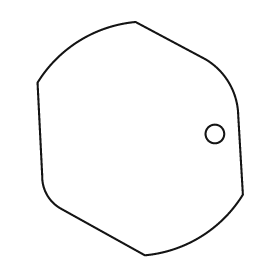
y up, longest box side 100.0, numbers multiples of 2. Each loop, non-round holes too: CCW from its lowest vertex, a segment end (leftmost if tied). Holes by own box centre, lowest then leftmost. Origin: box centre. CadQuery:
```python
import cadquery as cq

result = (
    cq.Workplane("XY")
    .moveTo(2.0, -50.0)
    .threePointArc((26.0, -42.0), (44.0, -24.0))
    .lineTo(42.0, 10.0)
    .threePointArc((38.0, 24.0), (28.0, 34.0))
    .lineTo(-2.0, 50.0)
    .threePointArc((-26.0, 42.0), (-44.0, 24.0))
    .lineTo(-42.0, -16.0)
    .threePointArc((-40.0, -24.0), (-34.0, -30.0))
    .close()
    .moveTo(32.0, 2.0)
    .circle(4.0)
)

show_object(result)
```